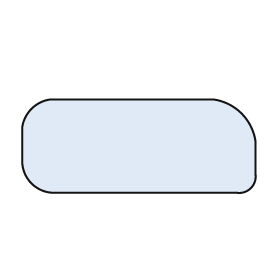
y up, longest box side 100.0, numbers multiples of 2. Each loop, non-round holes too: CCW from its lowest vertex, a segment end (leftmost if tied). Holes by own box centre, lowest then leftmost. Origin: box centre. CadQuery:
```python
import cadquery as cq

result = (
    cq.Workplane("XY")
    .moveTo(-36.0, -20.0)
    .lineTo(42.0, -20.0)
    .threePointArc((48.0, -18.0), (50.0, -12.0))
    .lineTo(50.0, 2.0)
    .threePointArc((44.0, 14.0), (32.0, 20.0))
    .lineTo(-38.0, 20.0)
    .threePointArc((-46.0, 16.0), (-50.0, 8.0))
    .lineTo(-50.0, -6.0)
    .threePointArc((-46.0, -16.0), (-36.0, -20.0))
    .close()
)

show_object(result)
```